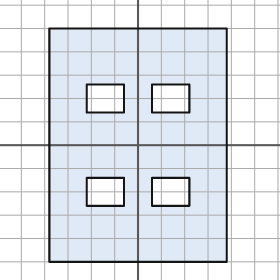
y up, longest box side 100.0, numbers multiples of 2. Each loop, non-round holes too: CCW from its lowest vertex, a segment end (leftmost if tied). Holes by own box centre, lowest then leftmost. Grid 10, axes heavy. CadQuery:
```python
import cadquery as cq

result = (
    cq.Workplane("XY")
    .moveTo(-38.0, -50.0)
    .lineTo(38.0, -50.0)
    .lineTo(38.0, 50.0)
    .lineTo(-38.0, 50.0)
    .close()
    .moveTo(-22.0, -26.0)
    .lineTo(-6.0, -26.0)
    .lineTo(-6.0, -14.0)
    .lineTo(-22.0, -14.0)
    .close()
    .moveTo(6.0, -26.0)
    .lineTo(22.0, -26.0)
    .lineTo(22.0, -14.0)
    .lineTo(6.0, -14.0)
    .close()
    .moveTo(-22.0, 14.0)
    .lineTo(-6.0, 14.0)
    .lineTo(-6.0, 26.0)
    .lineTo(-22.0, 26.0)
    .close()
    .moveTo(6.0, 14.0)
    .lineTo(22.0, 14.0)
    .lineTo(22.0, 26.0)
    .lineTo(6.0, 26.0)
    .close()
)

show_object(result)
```